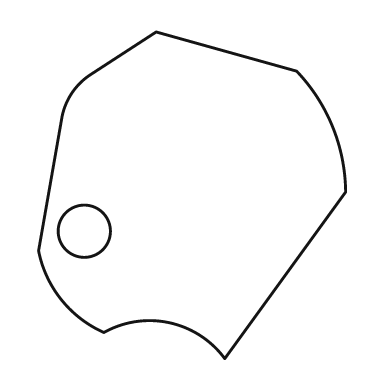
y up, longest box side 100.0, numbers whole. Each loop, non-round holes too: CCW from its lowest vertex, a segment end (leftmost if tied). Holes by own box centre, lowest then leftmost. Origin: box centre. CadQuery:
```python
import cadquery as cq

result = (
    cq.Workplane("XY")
    .moveTo(10.0, -50.0)
    .lineTo(47.0, 1.0)
    .threePointArc((43.0, 21.0), (32.0, 38.0))
    .lineTo(-11.0, 50.0)
    .lineTo(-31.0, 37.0)
    .threePointArc((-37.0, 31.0), (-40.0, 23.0))
    .lineTo(-47.0, -17.0)
    .threePointArc((-40.0, -32.0), (-27.0, -42.0))
    .threePointArc((-7.0, -39.0), (10.0, -50.0))
    .close()
    .moveTo(-33.0, -11.0)
    .circle(8.0)
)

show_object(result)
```